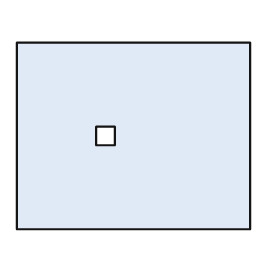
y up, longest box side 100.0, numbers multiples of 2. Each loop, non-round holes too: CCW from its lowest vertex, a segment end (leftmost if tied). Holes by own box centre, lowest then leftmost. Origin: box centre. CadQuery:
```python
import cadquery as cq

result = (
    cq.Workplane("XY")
    .moveTo(-50.0, -40.0)
    .lineTo(50.0, -40.0)
    .lineTo(50.0, 40.0)
    .lineTo(-50.0, 40.0)
    .close()
    .moveTo(-16.0, -4.0)
    .lineTo(-8.0, -4.0)
    .lineTo(-8.0, 4.0)
    .lineTo(-16.0, 4.0)
    .close()
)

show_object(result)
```